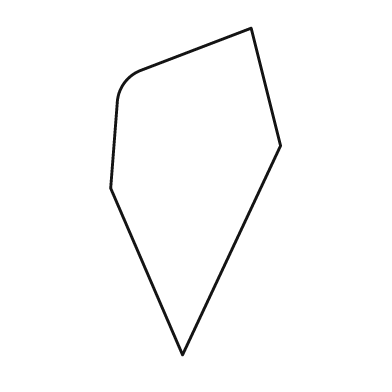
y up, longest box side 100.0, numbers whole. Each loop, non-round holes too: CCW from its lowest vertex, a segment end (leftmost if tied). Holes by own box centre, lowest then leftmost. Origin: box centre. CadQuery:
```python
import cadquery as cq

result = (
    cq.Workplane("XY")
    .moveTo(-4.0, -50.0)
    .lineTo(26.0, 14.0)
    .lineTo(17.0, 50.0)
    .lineTo(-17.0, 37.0)
    .threePointArc((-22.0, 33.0), (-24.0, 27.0))
    .lineTo(-26.0, 1.0)
    .close()
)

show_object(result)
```